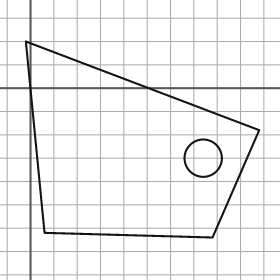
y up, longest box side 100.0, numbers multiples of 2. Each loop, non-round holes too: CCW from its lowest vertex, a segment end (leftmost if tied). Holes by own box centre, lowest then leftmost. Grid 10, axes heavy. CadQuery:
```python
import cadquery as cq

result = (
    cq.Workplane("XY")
    .moveTo(78.0, -64.0)
    .lineTo(98.0, -18.0)
    .lineTo(-2.0, 20.0)
    .lineTo(6.0, -62.0)
    .close()
    .moveTo(74.0, -30.0)
    .circle(8.0)
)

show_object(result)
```